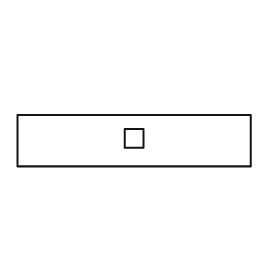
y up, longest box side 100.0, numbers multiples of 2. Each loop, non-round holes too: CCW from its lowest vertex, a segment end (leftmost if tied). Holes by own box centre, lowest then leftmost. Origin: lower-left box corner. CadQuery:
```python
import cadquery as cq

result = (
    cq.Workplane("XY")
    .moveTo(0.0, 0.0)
    .lineTo(100.0, 0.0)
    .lineTo(100.0, 22.0)
    .lineTo(0.0, 22.0)
    .close()
    .moveTo(46.0, 8.0)
    .lineTo(54.0, 8.0)
    .lineTo(54.0, 16.0)
    .lineTo(46.0, 16.0)
    .close()
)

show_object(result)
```